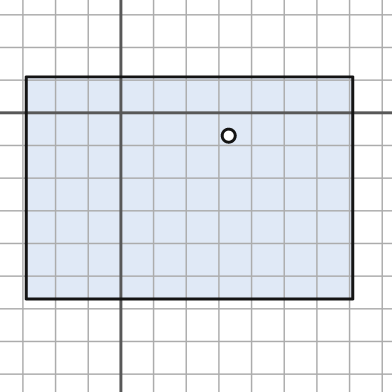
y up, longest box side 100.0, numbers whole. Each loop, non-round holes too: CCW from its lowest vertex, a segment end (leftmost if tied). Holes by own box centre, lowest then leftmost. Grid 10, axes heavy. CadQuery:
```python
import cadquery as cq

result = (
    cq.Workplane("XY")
    .moveTo(-29.0, -57.0)
    .lineTo(71.0, -57.0)
    .lineTo(71.0, 11.0)
    .lineTo(-29.0, 11.0)
    .close()
    .moveTo(33.0, -7.0)
    .circle(2.0)
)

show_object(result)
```